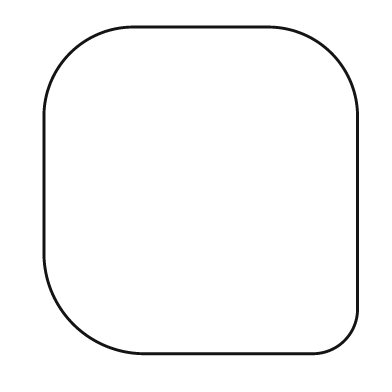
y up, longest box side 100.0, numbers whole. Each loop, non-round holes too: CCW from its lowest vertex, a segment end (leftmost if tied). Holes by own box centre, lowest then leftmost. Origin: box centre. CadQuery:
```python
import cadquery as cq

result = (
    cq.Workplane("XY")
    .moveTo(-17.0, -50.0)
    .lineTo(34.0, -50.0)
    .threePointArc((44.0, -46.0), (48.0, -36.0))
    .lineTo(48.0, 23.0)
    .threePointArc((40.0, 42.0), (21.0, 50.0))
    .lineTo(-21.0, 50.0)
    .threePointArc((-40.0, 42.0), (-48.0, 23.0))
    .lineTo(-48.0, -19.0)
    .threePointArc((-39.0, -41.0), (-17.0, -50.0))
    .close()
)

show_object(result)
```